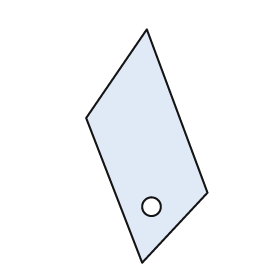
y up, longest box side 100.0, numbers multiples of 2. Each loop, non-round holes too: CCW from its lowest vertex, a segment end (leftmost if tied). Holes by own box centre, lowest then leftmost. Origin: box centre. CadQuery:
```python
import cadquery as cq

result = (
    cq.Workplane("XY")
    .moveTo(-2.0, -50.0)
    .lineTo(26.0, -20.0)
    .lineTo(0.0, 50.0)
    .lineTo(-26.0, 12.0)
    .close()
    .moveTo(2.0, -26.0)
    .circle(4.0)
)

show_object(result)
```